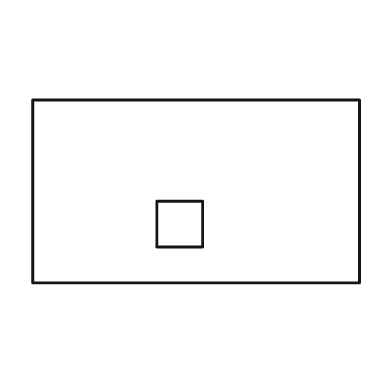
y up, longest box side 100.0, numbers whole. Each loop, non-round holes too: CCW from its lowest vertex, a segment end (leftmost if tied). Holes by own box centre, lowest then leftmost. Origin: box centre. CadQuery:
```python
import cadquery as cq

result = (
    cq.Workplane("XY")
    .moveTo(-50.0, -28.0)
    .lineTo(50.0, -28.0)
    .lineTo(50.0, 28.0)
    .lineTo(-50.0, 28.0)
    .close()
    .moveTo(-12.0, -17.0)
    .lineTo(2.0, -17.0)
    .lineTo(2.0, -3.0)
    .lineTo(-12.0, -3.0)
    .close()
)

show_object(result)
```